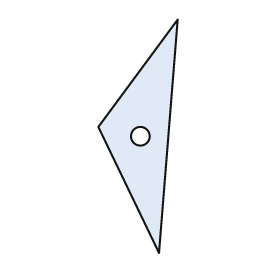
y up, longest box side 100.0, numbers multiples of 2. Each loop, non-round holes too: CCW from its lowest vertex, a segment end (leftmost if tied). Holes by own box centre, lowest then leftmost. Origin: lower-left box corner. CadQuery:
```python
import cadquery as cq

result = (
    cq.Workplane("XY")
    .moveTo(26.0, 0.0)
    .lineTo(34.0, 100.0)
    .lineTo(0.0, 54.0)
    .close()
    .moveTo(18.0, 50.0)
    .circle(4.0)
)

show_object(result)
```